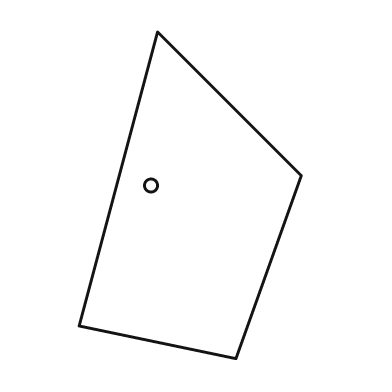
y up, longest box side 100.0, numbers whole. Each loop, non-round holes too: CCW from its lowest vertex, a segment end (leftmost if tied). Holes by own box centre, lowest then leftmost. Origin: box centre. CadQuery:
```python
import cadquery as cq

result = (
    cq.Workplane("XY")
    .moveTo(14.0, -50.0)
    .lineTo(34.0, 6.0)
    .lineTo(-10.0, 50.0)
    .lineTo(-34.0, -40.0)
    .close()
    .moveTo(-12.0, 3.0)
    .circle(2.0)
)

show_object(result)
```